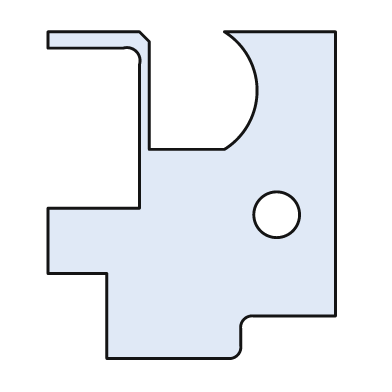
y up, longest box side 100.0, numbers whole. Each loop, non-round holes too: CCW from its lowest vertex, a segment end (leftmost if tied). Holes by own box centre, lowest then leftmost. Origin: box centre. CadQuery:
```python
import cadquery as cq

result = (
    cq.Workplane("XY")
    .moveTo(-26.0, -50.0)
    .lineTo(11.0, -50.0)
    .threePointArc((14.0, -49.0), (15.0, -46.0))
    .lineTo(15.0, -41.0)
    .threePointArc((16.0, -38.0), (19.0, -37.0))
    .lineTo(44.0, -37.0)
    .lineTo(44.0, 50.0)
    .lineTo(10.0, 50.0)
    .threePointArc((20.0, 32.0), (10.0, 14.0))
    .lineTo(-13.0, 14.0)
    .lineTo(-13.0, 47.0)
    .lineTo(-16.0, 50.0)
    .lineTo(-44.0, 50.0)
    .lineTo(-44.0, 45.0)
    .lineTo(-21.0, 45.0)
    .threePointArc((-17.0, 44.0), (-16.0, 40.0))
    .lineTo(-16.0, -4.0)
    .lineTo(-44.0, -4.0)
    .lineTo(-44.0, -24.0)
    .lineTo(-26.0, -24.0)
    .close()
    .moveTo(26.0, -6.0)
    .circle(7.0)
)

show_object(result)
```